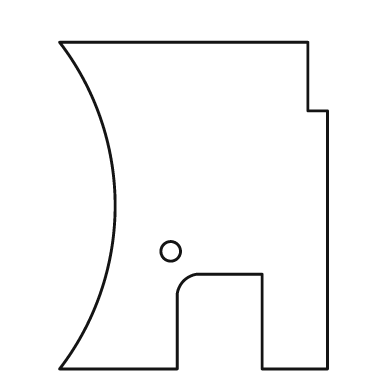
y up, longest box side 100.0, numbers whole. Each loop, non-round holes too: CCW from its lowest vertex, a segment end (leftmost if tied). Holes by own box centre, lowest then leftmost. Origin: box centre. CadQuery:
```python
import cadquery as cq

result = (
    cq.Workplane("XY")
    .moveTo(-41.0, -50.0)
    .lineTo(-5.0, -50.0)
    .lineTo(-5.0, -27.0)
    .threePointArc((-3.0, -23.0), (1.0, -21.0))
    .lineTo(21.0, -21.0)
    .lineTo(21.0, -50.0)
    .lineTo(41.0, -50.0)
    .lineTo(41.0, 29.0)
    .lineTo(35.0, 29.0)
    .lineTo(35.0, 50.0)
    .lineTo(-41.0, 50.0)
    .threePointArc((-24.0, 0.0), (-41.0, -50.0))
    .close()
    .moveTo(-7.0, -14.0)
    .circle(3.0)
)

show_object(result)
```